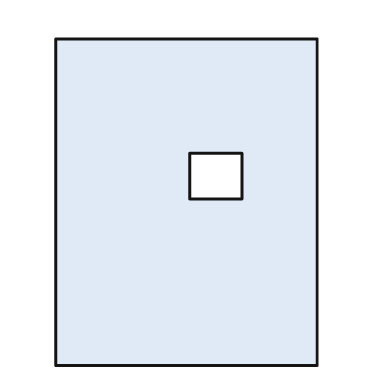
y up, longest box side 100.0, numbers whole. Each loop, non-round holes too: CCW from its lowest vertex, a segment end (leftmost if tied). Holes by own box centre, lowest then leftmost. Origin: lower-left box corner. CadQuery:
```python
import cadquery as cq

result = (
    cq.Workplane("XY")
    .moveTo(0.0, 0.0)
    .lineTo(80.0, 0.0)
    .lineTo(80.0, 100.0)
    .lineTo(0.0, 100.0)
    .close()
    .moveTo(41.0, 51.0)
    .lineTo(57.0, 51.0)
    .lineTo(57.0, 65.0)
    .lineTo(41.0, 65.0)
    .close()
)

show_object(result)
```